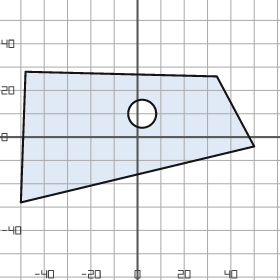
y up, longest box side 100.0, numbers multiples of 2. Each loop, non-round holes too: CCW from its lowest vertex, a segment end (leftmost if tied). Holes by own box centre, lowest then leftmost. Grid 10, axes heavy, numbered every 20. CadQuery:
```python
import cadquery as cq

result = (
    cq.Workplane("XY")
    .moveTo(-50.0, -28.0)
    .lineTo(50.0, -4.0)
    .lineTo(34.0, 26.0)
    .lineTo(-48.0, 28.0)
    .close()
    .moveTo(2.0, 10.0)
    .circle(6.0)
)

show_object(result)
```